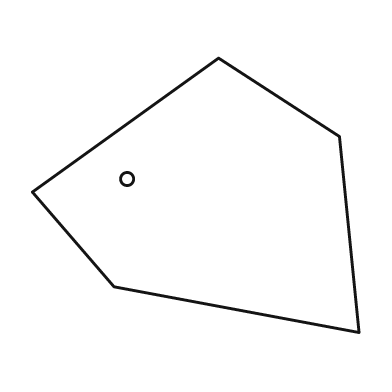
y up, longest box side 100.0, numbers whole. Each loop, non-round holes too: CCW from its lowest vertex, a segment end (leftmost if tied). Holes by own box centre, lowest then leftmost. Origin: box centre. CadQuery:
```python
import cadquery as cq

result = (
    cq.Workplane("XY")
    .moveTo(50.0, -42.0)
    .lineTo(44.0, 18.0)
    .lineTo(7.0, 42.0)
    .lineTo(-50.0, 1.0)
    .lineTo(-25.0, -28.0)
    .close()
    .moveTo(-21.0, 5.0)
    .circle(2.0)
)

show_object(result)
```